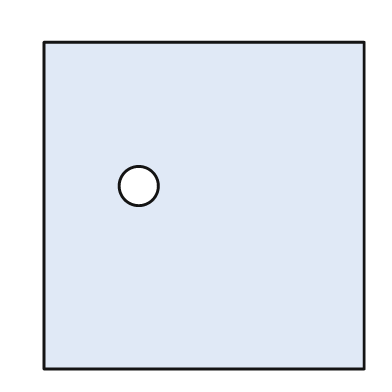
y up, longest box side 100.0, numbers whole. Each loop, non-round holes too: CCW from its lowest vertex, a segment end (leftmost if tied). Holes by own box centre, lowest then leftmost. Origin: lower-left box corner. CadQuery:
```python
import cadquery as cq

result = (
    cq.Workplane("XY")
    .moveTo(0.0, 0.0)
    .lineTo(98.0, 0.0)
    .lineTo(98.0, 100.0)
    .lineTo(0.0, 100.0)
    .close()
    .moveTo(29.0, 56.0)
    .circle(6.0)
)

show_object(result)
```